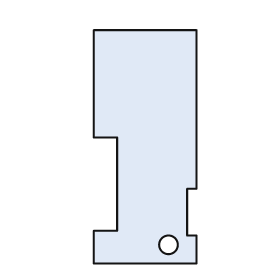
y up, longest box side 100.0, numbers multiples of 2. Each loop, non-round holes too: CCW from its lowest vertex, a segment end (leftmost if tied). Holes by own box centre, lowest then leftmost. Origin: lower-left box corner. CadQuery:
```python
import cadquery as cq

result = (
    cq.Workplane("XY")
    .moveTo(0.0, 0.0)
    .lineTo(44.0, 0.0)
    .lineTo(44.0, 12.0)
    .lineTo(40.0, 12.0)
    .lineTo(40.0, 32.0)
    .lineTo(44.0, 32.0)
    .lineTo(44.0, 100.0)
    .lineTo(0.0, 100.0)
    .lineTo(0.0, 54.0)
    .lineTo(10.0, 54.0)
    .lineTo(10.0, 14.0)
    .lineTo(0.0, 14.0)
    .close()
    .moveTo(32.0, 8.0)
    .circle(4.0)
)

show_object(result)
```